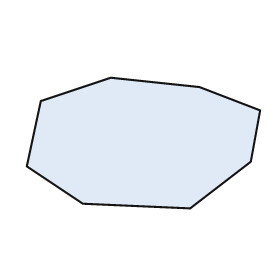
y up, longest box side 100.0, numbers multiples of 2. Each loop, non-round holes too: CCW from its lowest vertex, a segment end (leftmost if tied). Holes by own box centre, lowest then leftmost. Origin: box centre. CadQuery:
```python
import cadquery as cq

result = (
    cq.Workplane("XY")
    .moveTo(20.0, -28.0)
    .lineTo(46.0, -8.0)
    .lineTo(50.0, 14.0)
    .lineTo(24.0, 24.0)
    .lineTo(-14.0, 28.0)
    .lineTo(-44.0, 18.0)
    .lineTo(-50.0, -10.0)
    .lineTo(-26.0, -26.0)
    .close()
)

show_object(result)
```